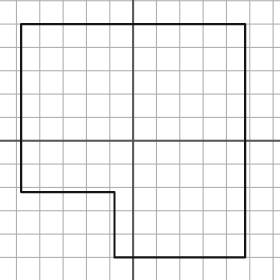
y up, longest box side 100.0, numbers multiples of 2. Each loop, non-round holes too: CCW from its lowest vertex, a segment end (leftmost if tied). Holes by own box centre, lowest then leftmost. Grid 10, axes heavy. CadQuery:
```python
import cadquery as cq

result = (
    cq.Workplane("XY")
    .moveTo(-8.0, -50.0)
    .lineTo(48.0, -50.0)
    .lineTo(48.0, 50.0)
    .lineTo(-48.0, 50.0)
    .lineTo(-48.0, -22.0)
    .lineTo(-8.0, -22.0)
    .close()
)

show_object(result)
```